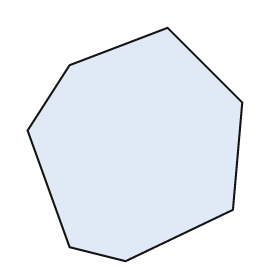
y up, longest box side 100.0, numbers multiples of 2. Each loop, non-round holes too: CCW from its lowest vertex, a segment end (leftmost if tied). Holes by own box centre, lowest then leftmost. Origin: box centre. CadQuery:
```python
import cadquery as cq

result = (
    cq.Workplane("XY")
    .moveTo(-4.0, -50.0)
    .lineTo(42.0, -28.0)
    .lineTo(46.0, 18.0)
    .lineTo(14.0, 50.0)
    .lineTo(-28.0, 34.0)
    .lineTo(-46.0, 6.0)
    .lineTo(-28.0, -44.0)
    .close()
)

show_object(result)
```